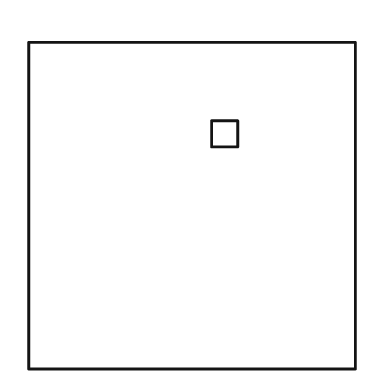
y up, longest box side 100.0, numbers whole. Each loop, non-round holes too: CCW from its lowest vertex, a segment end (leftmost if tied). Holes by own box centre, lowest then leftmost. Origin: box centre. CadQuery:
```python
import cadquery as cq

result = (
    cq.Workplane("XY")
    .moveTo(-50.0, -50.0)
    .lineTo(50.0, -50.0)
    .lineTo(50.0, 50.0)
    .lineTo(-50.0, 50.0)
    .close()
    .moveTo(6.0, 18.0)
    .lineTo(14.0, 18.0)
    .lineTo(14.0, 26.0)
    .lineTo(6.0, 26.0)
    .close()
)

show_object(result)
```